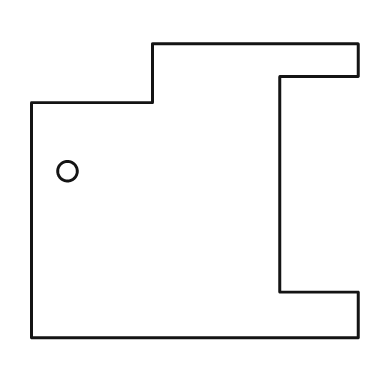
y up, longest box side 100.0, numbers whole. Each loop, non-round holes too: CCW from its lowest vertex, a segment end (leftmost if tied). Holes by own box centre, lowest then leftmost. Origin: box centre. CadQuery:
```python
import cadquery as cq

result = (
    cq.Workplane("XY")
    .moveTo(-50.0, -45.0)
    .lineTo(50.0, -45.0)
    .lineTo(50.0, -31.0)
    .lineTo(26.0, -31.0)
    .lineTo(26.0, 35.0)
    .lineTo(50.0, 35.0)
    .lineTo(50.0, 45.0)
    .lineTo(-13.0, 45.0)
    .lineTo(-13.0, 27.0)
    .lineTo(-50.0, 27.0)
    .close()
    .moveTo(-39.0, 6.0)
    .circle(3.0)
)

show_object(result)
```